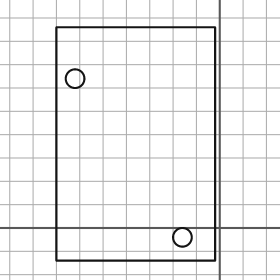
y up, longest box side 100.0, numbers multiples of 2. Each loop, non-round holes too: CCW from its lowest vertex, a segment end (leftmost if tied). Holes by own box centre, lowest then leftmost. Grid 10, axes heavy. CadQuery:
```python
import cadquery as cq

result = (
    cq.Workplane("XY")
    .moveTo(-70.0, -14.0)
    .lineTo(-2.0, -14.0)
    .lineTo(-2.0, 86.0)
    .lineTo(-70.0, 86.0)
    .close()
    .moveTo(-16.0, -4.0)
    .circle(4.0)
    .moveTo(-62.0, 64.0)
    .circle(4.0)
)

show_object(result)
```